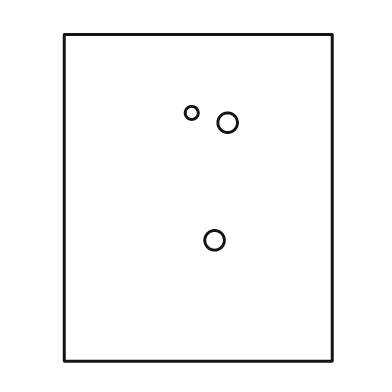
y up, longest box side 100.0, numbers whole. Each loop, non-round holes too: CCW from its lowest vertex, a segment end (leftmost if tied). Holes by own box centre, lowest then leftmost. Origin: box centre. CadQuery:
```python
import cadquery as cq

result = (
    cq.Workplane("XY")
    .moveTo(-41.0, -50.0)
    .lineTo(41.0, -50.0)
    .lineTo(41.0, 50.0)
    .lineTo(-41.0, 50.0)
    .close()
    .moveTo(5.0, -13.0)
    .circle(3.0)
    .moveTo(9.0, 23.0)
    .circle(3.0)
    .moveTo(-2.0, 26.0)
    .circle(2.0)
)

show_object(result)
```